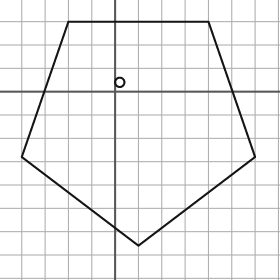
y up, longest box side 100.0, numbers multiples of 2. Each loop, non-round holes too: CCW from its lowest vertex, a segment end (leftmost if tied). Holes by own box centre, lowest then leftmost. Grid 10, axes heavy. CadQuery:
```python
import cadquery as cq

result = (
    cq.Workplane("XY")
    .moveTo(10.0, -66.0)
    .lineTo(60.0, -28.0)
    .lineTo(40.0, 30.0)
    .lineTo(-20.0, 30.0)
    .lineTo(-40.0, -28.0)
    .close()
    .moveTo(2.0, 4.0)
    .circle(2.0)
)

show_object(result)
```